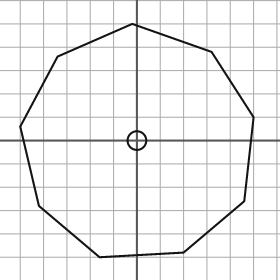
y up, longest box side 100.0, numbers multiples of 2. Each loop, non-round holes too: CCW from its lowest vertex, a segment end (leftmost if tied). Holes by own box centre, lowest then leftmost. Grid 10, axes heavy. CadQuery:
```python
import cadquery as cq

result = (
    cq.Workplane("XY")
    .moveTo(-16.0, -50.0)
    .lineTo(20.0, -48.0)
    .lineTo(46.0, -26.0)
    .lineTo(50.0, 10.0)
    .lineTo(32.0, 38.0)
    .lineTo(-2.0, 50.0)
    .lineTo(-34.0, 36.0)
    .lineTo(-50.0, 6.0)
    .lineTo(-42.0, -28.0)
    .close()
    .moveTo(0.0, 0.0)
    .circle(4.0)
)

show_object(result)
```